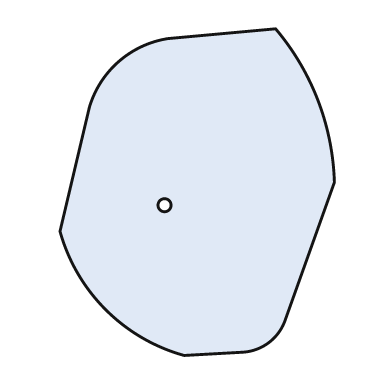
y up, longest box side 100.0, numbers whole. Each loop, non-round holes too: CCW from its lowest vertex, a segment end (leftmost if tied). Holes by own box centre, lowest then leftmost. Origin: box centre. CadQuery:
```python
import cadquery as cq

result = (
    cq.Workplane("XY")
    .moveTo(-4.0, -50.0)
    .lineTo(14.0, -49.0)
    .threePointArc((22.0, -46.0), (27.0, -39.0))
    .lineTo(42.0, 3.0)
    .threePointArc((37.0, 28.0), (24.0, 50.0))
    .lineTo(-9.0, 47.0)
    .threePointArc((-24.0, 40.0), (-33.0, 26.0))
    .lineTo(-42.0, -12.0)
    .threePointArc((-28.0, -36.0), (-4.0, -50.0))
    .close()
    .moveTo(-10.0, -4.0)
    .circle(2.0)
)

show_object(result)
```